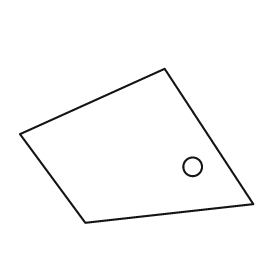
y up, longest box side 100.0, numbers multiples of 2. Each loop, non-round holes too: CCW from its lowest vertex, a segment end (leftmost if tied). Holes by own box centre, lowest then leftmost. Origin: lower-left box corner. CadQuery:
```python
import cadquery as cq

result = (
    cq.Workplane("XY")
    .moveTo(28.0, 0.0)
    .lineTo(100.0, 8.0)
    .lineTo(62.0, 66.0)
    .lineTo(0.0, 38.0)
    .close()
    .moveTo(74.0, 24.0)
    .circle(4.0)
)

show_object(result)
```